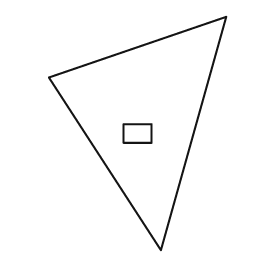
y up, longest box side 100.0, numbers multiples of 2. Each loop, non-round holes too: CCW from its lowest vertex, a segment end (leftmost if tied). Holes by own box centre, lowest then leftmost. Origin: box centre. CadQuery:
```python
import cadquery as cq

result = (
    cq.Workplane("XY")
    .moveTo(10.0, -50.0)
    .lineTo(38.0, 50.0)
    .lineTo(-38.0, 24.0)
    .close()
    .moveTo(-6.0, -4.0)
    .lineTo(6.0, -4.0)
    .lineTo(6.0, 4.0)
    .lineTo(-6.0, 4.0)
    .close()
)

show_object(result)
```